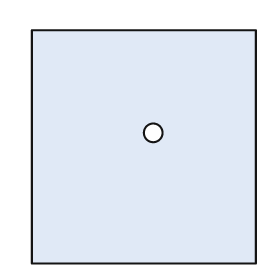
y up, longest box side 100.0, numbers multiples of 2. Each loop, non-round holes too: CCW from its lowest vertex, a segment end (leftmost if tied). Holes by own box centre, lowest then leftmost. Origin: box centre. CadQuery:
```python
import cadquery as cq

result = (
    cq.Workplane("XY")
    .moveTo(-48.0, -50.0)
    .lineTo(48.0, -50.0)
    .lineTo(48.0, 50.0)
    .lineTo(-48.0, 50.0)
    .close()
    .moveTo(4.0, 6.0)
    .circle(4.0)
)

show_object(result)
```